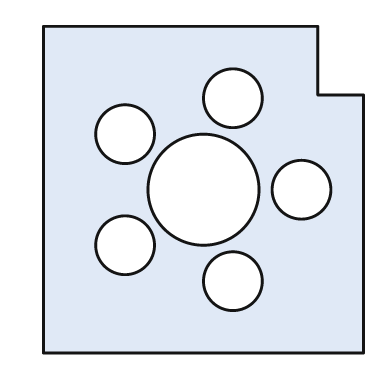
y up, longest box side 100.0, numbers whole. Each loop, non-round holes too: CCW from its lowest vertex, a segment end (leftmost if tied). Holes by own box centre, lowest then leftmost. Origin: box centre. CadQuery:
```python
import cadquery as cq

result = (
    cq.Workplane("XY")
    .moveTo(-49.0, -50.0)
    .lineTo(49.0, -50.0)
    .lineTo(49.0, 29.0)
    .lineTo(35.0, 29.0)
    .lineTo(35.0, 50.0)
    .lineTo(-49.0, 50.0)
    .close()
    .moveTo(9.0, -28.0)
    .circle(9.0)
    .moveTo(-24.0, -17.0)
    .circle(9.0)
    .moveTo(0.0, 0.0)
    .circle(17.0)
    .moveTo(30.0, 0.0)
    .circle(9.0)
    .moveTo(-24.0, 17.0)
    .circle(9.0)
    .moveTo(9.0, 28.0)
    .circle(9.0)
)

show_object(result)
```